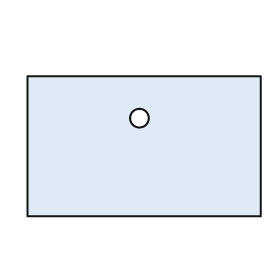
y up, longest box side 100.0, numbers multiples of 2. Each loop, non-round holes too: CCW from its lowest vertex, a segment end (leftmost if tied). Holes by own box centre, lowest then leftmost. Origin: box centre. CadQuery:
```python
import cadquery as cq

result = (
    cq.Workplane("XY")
    .moveTo(-50.0, -30.0)
    .lineTo(50.0, -30.0)
    .lineTo(50.0, 30.0)
    .lineTo(-50.0, 30.0)
    .close()
    .moveTo(-2.0, 12.0)
    .circle(4.0)
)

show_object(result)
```